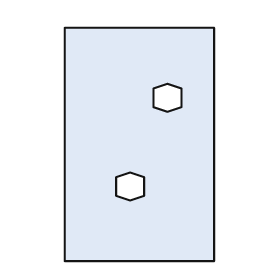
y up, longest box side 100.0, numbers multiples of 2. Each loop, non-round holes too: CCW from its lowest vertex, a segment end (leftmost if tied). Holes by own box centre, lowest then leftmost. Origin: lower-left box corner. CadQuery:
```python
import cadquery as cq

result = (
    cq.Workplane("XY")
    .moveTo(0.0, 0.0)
    .lineTo(64.0, 0.0)
    .lineTo(64.0, 100.0)
    .lineTo(0.0, 100.0)
    .close()
    .moveTo(28.0, 26.0)
    .lineTo(34.0, 28.0)
    .lineTo(34.0, 36.0)
    .lineTo(28.0, 38.0)
    .lineTo(22.0, 36.0)
    .lineTo(22.0, 28.0)
    .close()
    .moveTo(44.0, 64.0)
    .lineTo(50.0, 66.0)
    .lineTo(50.0, 74.0)
    .lineTo(44.0, 76.0)
    .lineTo(38.0, 74.0)
    .lineTo(38.0, 66.0)
    .close()
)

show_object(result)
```